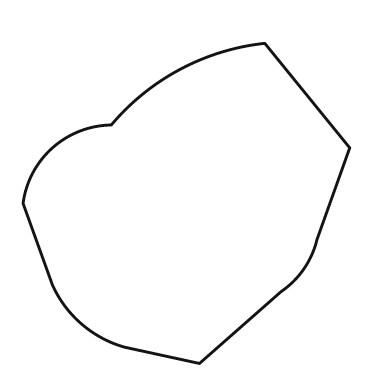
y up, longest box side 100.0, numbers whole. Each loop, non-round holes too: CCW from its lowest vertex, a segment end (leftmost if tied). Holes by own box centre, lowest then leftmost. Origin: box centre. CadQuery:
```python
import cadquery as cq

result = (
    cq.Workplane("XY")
    .moveTo(4.0, -49.0)
    .lineTo(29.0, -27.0)
    .threePointArc((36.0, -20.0), (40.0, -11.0))
    .lineTo(50.0, 17.0)
    .lineTo(24.0, 49.0)
    .threePointArc((-2.0, 41.0), (-23.0, 24.0))
    .threePointArc((-41.0, 17.0), (-50.0, 0.0))
    .lineTo(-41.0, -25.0)
    .threePointArc((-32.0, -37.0), (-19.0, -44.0))
    .close()
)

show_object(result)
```